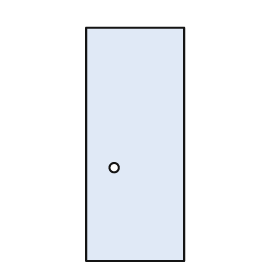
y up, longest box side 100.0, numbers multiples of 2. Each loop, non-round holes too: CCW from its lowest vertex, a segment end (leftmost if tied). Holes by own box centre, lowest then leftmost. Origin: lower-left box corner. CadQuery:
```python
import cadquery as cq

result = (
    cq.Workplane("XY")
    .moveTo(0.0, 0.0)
    .lineTo(42.0, 0.0)
    .lineTo(42.0, 100.0)
    .lineTo(0.0, 100.0)
    .close()
    .moveTo(12.0, 40.0)
    .circle(2.0)
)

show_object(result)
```